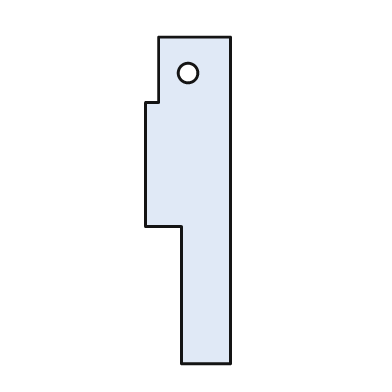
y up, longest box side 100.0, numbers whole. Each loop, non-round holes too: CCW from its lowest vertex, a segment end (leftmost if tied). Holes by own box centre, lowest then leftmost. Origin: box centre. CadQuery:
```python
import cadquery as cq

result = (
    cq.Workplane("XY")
    .moveTo(-2.0, -50.0)
    .lineTo(13.0, -50.0)
    .lineTo(13.0, 50.0)
    .lineTo(-9.0, 50.0)
    .lineTo(-9.0, 30.0)
    .lineTo(-13.0, 30.0)
    .lineTo(-13.0, -8.0)
    .lineTo(-2.0, -8.0)
    .close()
    .moveTo(0.0, 39.0)
    .circle(3.0)
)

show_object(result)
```